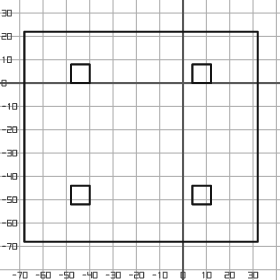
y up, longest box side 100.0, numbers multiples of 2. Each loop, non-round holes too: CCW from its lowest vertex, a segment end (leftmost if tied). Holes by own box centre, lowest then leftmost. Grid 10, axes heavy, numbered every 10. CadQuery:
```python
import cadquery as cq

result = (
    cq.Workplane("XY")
    .moveTo(-68.0, -68.0)
    .lineTo(32.0, -68.0)
    .lineTo(32.0, 22.0)
    .lineTo(-68.0, 22.0)
    .close()
    .moveTo(-48.0, -52.0)
    .lineTo(-40.0, -52.0)
    .lineTo(-40.0, -44.0)
    .lineTo(-48.0, -44.0)
    .close()
    .moveTo(4.0, -52.0)
    .lineTo(12.0, -52.0)
    .lineTo(12.0, -44.0)
    .lineTo(4.0, -44.0)
    .close()
    .moveTo(-48.0, 0.0)
    .lineTo(-40.0, 0.0)
    .lineTo(-40.0, 8.0)
    .lineTo(-48.0, 8.0)
    .close()
    .moveTo(4.0, 0.0)
    .lineTo(12.0, 0.0)
    .lineTo(12.0, 8.0)
    .lineTo(4.0, 8.0)
    .close()
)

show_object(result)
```